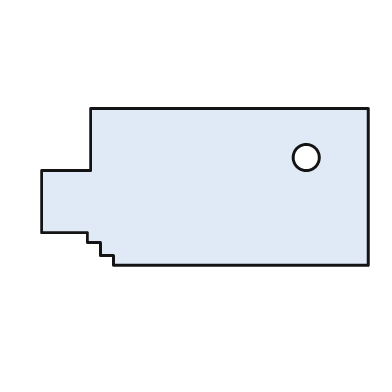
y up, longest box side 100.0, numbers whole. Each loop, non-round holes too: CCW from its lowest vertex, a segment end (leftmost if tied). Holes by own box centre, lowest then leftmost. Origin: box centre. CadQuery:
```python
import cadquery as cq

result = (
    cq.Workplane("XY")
    .moveTo(-28.0, -24.0)
    .lineTo(50.0, -24.0)
    .lineTo(50.0, 24.0)
    .lineTo(-35.0, 24.0)
    .lineTo(-35.0, 5.0)
    .lineTo(-50.0, 5.0)
    .lineTo(-50.0, -14.0)
    .lineTo(-36.0, -14.0)
    .lineTo(-36.0, -17.0)
    .lineTo(-32.0, -17.0)
    .lineTo(-32.0, -21.0)
    .lineTo(-28.0, -21.0)
    .close()
    .moveTo(31.0, 9.0)
    .circle(4.0)
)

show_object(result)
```